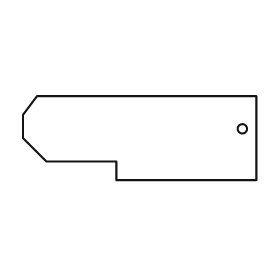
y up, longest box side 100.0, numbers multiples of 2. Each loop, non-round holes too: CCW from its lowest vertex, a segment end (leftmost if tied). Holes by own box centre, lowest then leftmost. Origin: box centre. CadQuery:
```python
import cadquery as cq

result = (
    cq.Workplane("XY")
    .moveTo(-10.0, -18.0)
    .lineTo(50.0, -18.0)
    .lineTo(50.0, 18.0)
    .lineTo(-44.0, 18.0)
    .lineTo(-50.0, 10.0)
    .lineTo(-50.0, 0.0)
    .lineTo(-40.0, -10.0)
    .lineTo(-10.0, -10.0)
    .close()
    .moveTo(44.0, 4.0)
    .circle(2.0)
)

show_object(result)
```